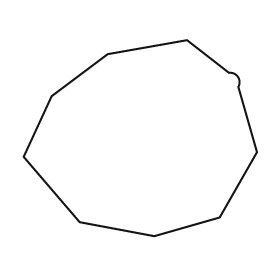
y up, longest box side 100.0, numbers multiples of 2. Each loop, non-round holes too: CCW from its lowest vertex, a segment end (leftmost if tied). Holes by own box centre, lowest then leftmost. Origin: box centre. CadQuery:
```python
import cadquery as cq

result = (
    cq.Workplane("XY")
    .moveTo(6.0, -42.0)
    .lineTo(34.0, -34.0)
    .lineTo(50.0, -6.0)
    .lineTo(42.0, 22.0)
    .threePointArc((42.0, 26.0), (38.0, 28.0))
    .lineTo(20.0, 42.0)
    .lineTo(-14.0, 36.0)
    .lineTo(-38.0, 18.0)
    .lineTo(-50.0, -8.0)
    .lineTo(-26.0, -36.0)
    .close()
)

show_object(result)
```